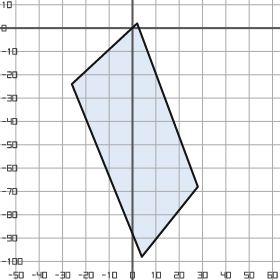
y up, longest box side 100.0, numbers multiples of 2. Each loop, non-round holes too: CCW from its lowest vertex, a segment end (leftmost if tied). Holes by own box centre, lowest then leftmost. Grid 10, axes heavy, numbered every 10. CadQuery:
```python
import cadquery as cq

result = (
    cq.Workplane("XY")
    .moveTo(4.0, -98.0)
    .lineTo(28.0, -68.0)
    .lineTo(2.0, 2.0)
    .lineTo(-26.0, -24.0)
    .close()
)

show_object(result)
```